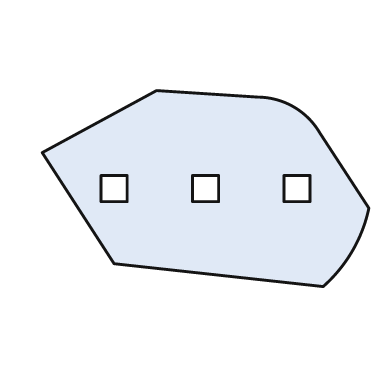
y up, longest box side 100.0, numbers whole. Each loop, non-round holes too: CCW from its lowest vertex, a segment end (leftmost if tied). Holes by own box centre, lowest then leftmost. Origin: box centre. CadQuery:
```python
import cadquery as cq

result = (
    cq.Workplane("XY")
    .moveTo(36.0, -30.0)
    .threePointArc((45.0, -19.0), (50.0, -6.0))
    .lineTo(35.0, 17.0)
    .threePointArc((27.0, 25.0), (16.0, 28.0))
    .lineTo(-15.0, 30.0)
    .lineTo(-50.0, 11.0)
    .lineTo(-28.0, -23.0)
    .close()
    .moveTo(-32.0, -4.0)
    .lineTo(-24.0, -4.0)
    .lineTo(-24.0, 4.0)
    .lineTo(-32.0, 4.0)
    .close()
    .moveTo(-4.0, -4.0)
    .lineTo(4.0, -4.0)
    .lineTo(4.0, 4.0)
    .lineTo(-4.0, 4.0)
    .close()
    .moveTo(24.0, -4.0)
    .lineTo(32.0, -4.0)
    .lineTo(32.0, 4.0)
    .lineTo(24.0, 4.0)
    .close()
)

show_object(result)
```